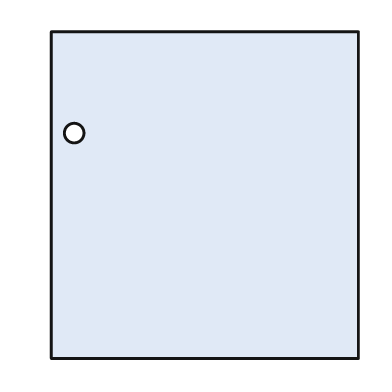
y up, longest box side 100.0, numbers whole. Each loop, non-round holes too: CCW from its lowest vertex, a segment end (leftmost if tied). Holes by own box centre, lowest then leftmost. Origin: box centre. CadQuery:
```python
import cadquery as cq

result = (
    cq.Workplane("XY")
    .moveTo(-47.0, -50.0)
    .lineTo(47.0, -50.0)
    .lineTo(47.0, 50.0)
    .lineTo(-47.0, 50.0)
    .close()
    .moveTo(-40.0, 19.0)
    .circle(3.0)
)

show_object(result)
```